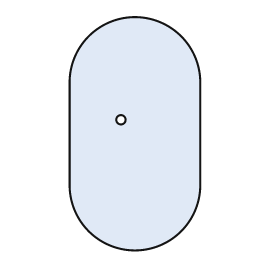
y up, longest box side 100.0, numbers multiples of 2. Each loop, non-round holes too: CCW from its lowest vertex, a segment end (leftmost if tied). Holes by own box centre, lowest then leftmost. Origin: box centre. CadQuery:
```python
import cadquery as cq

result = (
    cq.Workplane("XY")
    .moveTo(-28.0, -22.0)
    .threePointArc((0.0, -50.0), (28.0, -22.0))
    .lineTo(28.0, 22.0)
    .threePointArc((0.0, 50.0), (-28.0, 22.0))
    .close()
    .moveTo(-6.0, 6.0)
    .circle(2.0)
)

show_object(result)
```